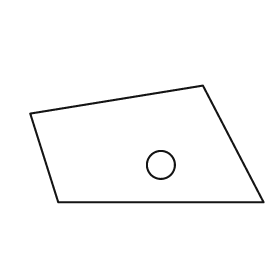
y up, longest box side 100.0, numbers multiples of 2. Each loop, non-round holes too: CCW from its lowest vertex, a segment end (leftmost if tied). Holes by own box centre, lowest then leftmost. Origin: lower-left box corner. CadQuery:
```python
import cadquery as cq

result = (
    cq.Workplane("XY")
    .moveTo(12.0, 0.0)
    .lineTo(100.0, 0.0)
    .lineTo(74.0, 50.0)
    .lineTo(0.0, 38.0)
    .close()
    .moveTo(56.0, 16.0)
    .circle(6.0)
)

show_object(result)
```